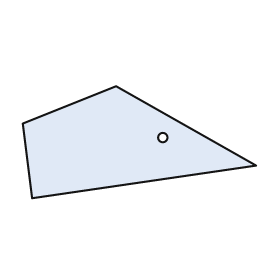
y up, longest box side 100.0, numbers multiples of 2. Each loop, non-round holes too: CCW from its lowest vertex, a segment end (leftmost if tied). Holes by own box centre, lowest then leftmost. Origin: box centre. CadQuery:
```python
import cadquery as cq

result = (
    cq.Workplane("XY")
    .moveTo(-46.0, -24.0)
    .lineTo(50.0, -10.0)
    .lineTo(-10.0, 24.0)
    .lineTo(-50.0, 8.0)
    .close()
    .moveTo(10.0, 2.0)
    .circle(2.0)
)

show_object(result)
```